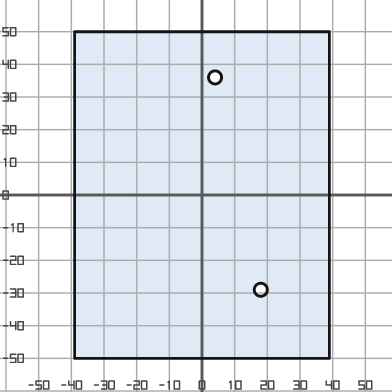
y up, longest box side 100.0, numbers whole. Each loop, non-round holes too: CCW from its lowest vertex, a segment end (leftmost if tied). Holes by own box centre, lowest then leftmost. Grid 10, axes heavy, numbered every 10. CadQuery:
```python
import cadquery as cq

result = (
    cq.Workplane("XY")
    .moveTo(-39.0, -50.0)
    .lineTo(39.0, -50.0)
    .lineTo(39.0, 50.0)
    .lineTo(-39.0, 50.0)
    .close()
    .moveTo(18.0, -29.0)
    .circle(2.0)
    .moveTo(4.0, 36.0)
    .circle(2.0)
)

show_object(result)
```